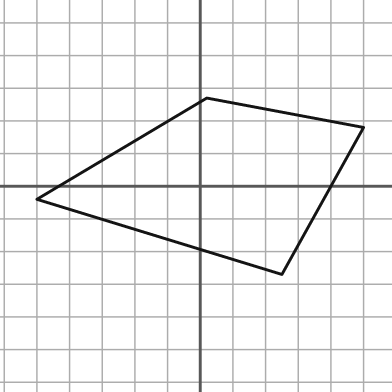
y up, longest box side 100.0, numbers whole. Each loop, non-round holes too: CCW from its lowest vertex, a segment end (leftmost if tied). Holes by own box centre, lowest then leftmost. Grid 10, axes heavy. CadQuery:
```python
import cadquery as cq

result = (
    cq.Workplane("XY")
    .moveTo(25.0, -27.0)
    .lineTo(50.0, 18.0)
    .lineTo(2.0, 27.0)
    .lineTo(-50.0, -4.0)
    .close()
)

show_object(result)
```